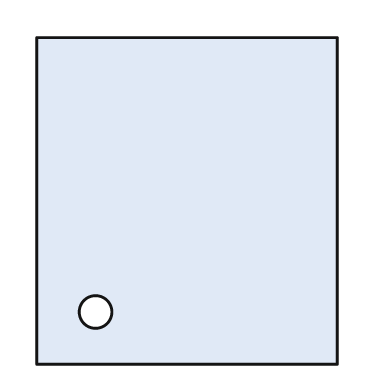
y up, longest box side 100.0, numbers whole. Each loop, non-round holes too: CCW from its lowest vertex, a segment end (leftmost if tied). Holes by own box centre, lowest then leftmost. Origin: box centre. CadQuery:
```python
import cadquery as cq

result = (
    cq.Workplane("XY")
    .moveTo(-46.0, -50.0)
    .lineTo(46.0, -50.0)
    .lineTo(46.0, 50.0)
    .lineTo(-46.0, 50.0)
    .close()
    .moveTo(-28.0, -34.0)
    .circle(5.0)
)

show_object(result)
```